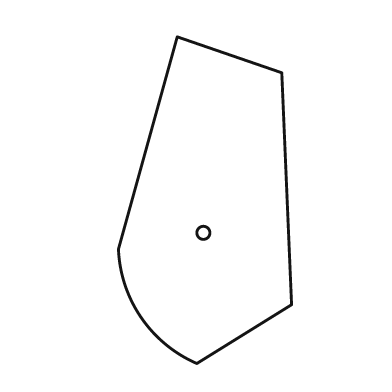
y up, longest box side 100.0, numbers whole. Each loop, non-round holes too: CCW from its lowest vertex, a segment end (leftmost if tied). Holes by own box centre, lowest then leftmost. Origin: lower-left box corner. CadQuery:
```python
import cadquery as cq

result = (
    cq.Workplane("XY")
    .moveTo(24.0, 0.0)
    .lineTo(53.0, 18.0)
    .lineTo(50.0, 89.0)
    .lineTo(18.0, 100.0)
    .lineTo(0.0, 35.0)
    .threePointArc((7.0, 14.0), (24.0, 0.0))
    .close()
    .moveTo(26.0, 40.0)
    .circle(2.0)
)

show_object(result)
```